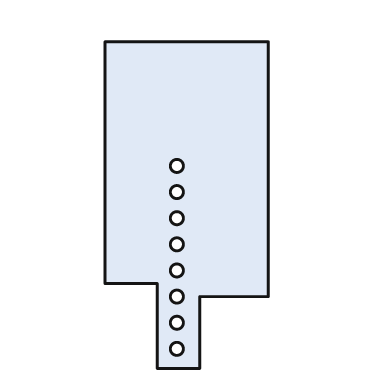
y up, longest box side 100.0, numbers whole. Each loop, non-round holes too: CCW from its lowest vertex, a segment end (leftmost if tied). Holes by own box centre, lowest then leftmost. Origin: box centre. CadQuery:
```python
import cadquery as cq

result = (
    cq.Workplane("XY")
    .moveTo(-9.0, -50.0)
    .lineTo(4.0, -50.0)
    .lineTo(4.0, -28.0)
    .lineTo(25.0, -28.0)
    .lineTo(25.0, 50.0)
    .lineTo(-25.0, 50.0)
    .lineTo(-25.0, -24.0)
    .lineTo(-9.0, -24.0)
    .close()
    .moveTo(-3.0, -44.0)
    .circle(2.0)
    .moveTo(-3.0, -36.0)
    .circle(2.0)
    .moveTo(-3.0, -28.0)
    .circle(2.0)
    .moveTo(-3.0, -20.0)
    .circle(2.0)
    .moveTo(-3.0, -12.0)
    .circle(2.0)
    .moveTo(-3.0, -4.0)
    .circle(2.0)
    .moveTo(-3.0, 4.0)
    .circle(2.0)
    .moveTo(-3.0, 12.0)
    .circle(2.0)
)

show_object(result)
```